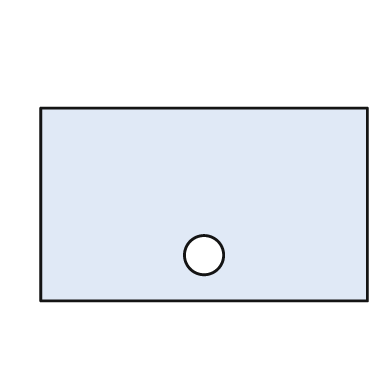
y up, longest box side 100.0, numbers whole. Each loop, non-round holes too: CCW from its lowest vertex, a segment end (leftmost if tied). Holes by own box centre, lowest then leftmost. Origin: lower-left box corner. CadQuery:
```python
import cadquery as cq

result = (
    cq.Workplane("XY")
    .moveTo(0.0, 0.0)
    .lineTo(100.0, 0.0)
    .lineTo(100.0, 59.0)
    .lineTo(0.0, 59.0)
    .close()
    .moveTo(50.0, 14.0)
    .circle(6.0)
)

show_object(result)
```